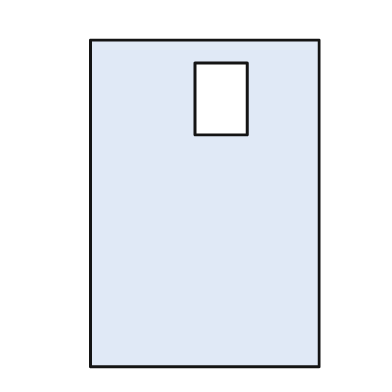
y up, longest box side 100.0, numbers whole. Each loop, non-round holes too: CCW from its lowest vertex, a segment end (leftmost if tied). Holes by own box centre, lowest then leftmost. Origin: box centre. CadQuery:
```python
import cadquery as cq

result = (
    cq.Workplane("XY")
    .moveTo(-35.0, -50.0)
    .lineTo(35.0, -50.0)
    .lineTo(35.0, 50.0)
    .lineTo(-35.0, 50.0)
    .close()
    .moveTo(-3.0, 21.0)
    .lineTo(13.0, 21.0)
    .lineTo(13.0, 43.0)
    .lineTo(-3.0, 43.0)
    .close()
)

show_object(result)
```